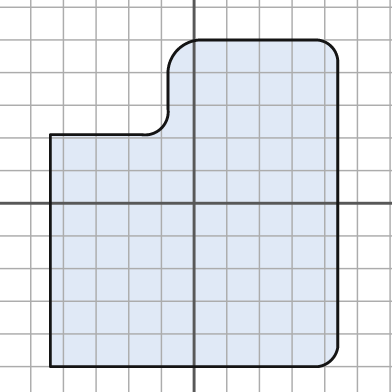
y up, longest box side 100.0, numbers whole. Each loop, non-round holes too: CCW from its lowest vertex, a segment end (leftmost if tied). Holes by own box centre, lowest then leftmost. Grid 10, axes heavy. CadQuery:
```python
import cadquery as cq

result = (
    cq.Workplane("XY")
    .moveTo(-44.0, -50.0)
    .lineTo(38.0, -50.0)
    .threePointArc((42.0, -48.0), (44.0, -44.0))
    .lineTo(44.0, 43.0)
    .threePointArc((42.0, 48.0), (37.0, 50.0))
    .lineTo(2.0, 50.0)
    .threePointArc((-5.0, 47.0), (-8.0, 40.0))
    .lineTo(-8.0, 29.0)
    .threePointArc((-10.0, 23.0), (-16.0, 21.0))
    .lineTo(-44.0, 21.0)
    .close()
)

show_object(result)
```